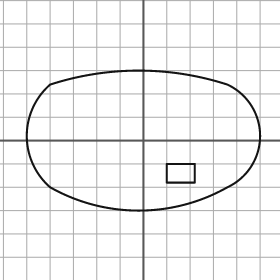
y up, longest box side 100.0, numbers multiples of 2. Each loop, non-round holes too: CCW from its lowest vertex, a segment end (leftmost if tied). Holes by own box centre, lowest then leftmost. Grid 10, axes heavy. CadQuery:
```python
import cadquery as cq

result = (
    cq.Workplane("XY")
    .moveTo(-40.0, -20.0)
    .threePointArc((-2.0, -30.0), (36.0, -20.0))
    .threePointArc((50.0, 2.0), (36.0, 24.0))
    .threePointArc((-2.0, 30.0), (-40.0, 24.0))
    .threePointArc((-50.0, 2.0), (-40.0, -20.0))
    .close()
    .moveTo(10.0, -18.0)
    .lineTo(22.0, -18.0)
    .lineTo(22.0, -10.0)
    .lineTo(10.0, -10.0)
    .close()
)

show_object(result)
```